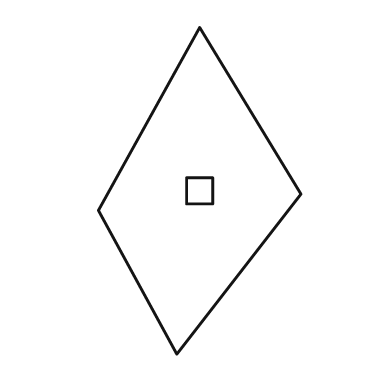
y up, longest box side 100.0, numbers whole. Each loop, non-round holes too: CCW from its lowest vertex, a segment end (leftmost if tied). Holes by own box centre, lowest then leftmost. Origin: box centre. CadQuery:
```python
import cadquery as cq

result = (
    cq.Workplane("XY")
    .moveTo(-7.0, -50.0)
    .lineTo(31.0, -1.0)
    .lineTo(0.0, 50.0)
    .lineTo(-31.0, -6.0)
    .close()
    .moveTo(-4.0, -4.0)
    .lineTo(4.0, -4.0)
    .lineTo(4.0, 4.0)
    .lineTo(-4.0, 4.0)
    .close()
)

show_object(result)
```